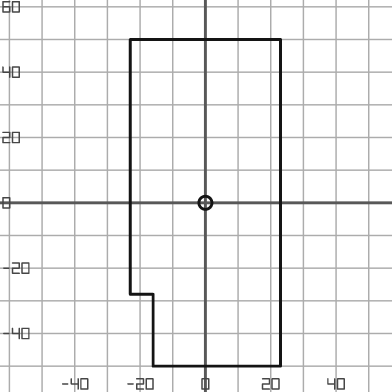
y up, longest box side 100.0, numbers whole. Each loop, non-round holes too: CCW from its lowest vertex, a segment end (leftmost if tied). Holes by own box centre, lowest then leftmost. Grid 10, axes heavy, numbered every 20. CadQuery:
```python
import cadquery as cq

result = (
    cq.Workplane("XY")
    .moveTo(-16.0, -50.0)
    .lineTo(23.0, -50.0)
    .lineTo(23.0, 50.0)
    .lineTo(-23.0, 50.0)
    .lineTo(-23.0, -28.0)
    .lineTo(-16.0, -28.0)
    .close()
    .moveTo(0.0, 0.0)
    .circle(2.0)
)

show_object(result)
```